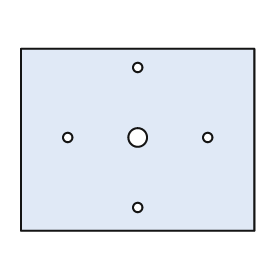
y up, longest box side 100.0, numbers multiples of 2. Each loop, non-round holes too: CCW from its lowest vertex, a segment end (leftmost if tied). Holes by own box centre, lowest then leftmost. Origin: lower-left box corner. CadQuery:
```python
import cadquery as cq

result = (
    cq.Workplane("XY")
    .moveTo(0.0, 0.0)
    .lineTo(100.0, 0.0)
    .lineTo(100.0, 78.0)
    .lineTo(0.0, 78.0)
    .close()
    .moveTo(50.0, 10.0)
    .circle(2.0)
    .moveTo(20.0, 40.0)
    .circle(2.0)
    .moveTo(50.0, 40.0)
    .circle(4.0)
    .moveTo(80.0, 40.0)
    .circle(2.0)
    .moveTo(50.0, 70.0)
    .circle(2.0)
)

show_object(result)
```